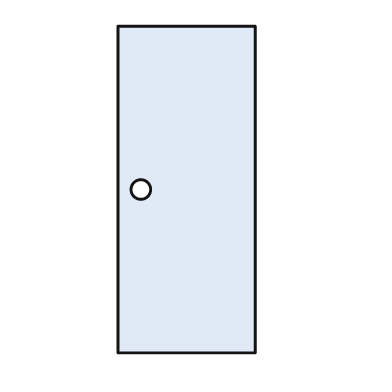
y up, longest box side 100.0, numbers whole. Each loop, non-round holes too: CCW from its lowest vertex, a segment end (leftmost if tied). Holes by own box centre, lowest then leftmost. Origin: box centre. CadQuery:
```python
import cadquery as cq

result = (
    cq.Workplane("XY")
    .moveTo(-21.0, -50.0)
    .lineTo(21.0, -50.0)
    .lineTo(21.0, 50.0)
    .lineTo(-21.0, 50.0)
    .close()
    .moveTo(-14.0, 0.0)
    .circle(3.0)
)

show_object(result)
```